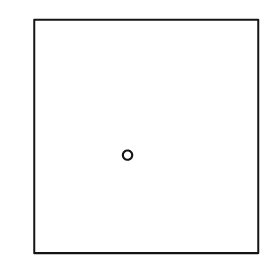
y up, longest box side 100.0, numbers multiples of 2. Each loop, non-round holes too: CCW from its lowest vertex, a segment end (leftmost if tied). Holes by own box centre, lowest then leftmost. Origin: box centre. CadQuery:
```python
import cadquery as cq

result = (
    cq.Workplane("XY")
    .moveTo(-48.0, -50.0)
    .lineTo(48.0, -50.0)
    .lineTo(48.0, 50.0)
    .lineTo(-48.0, 50.0)
    .close()
    .moveTo(-8.0, -8.0)
    .circle(2.0)
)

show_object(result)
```